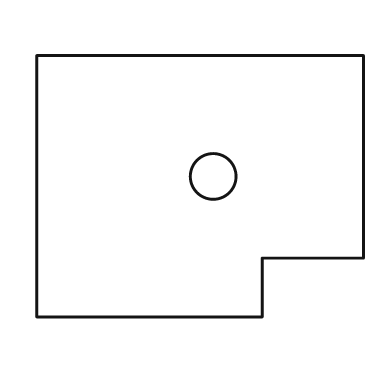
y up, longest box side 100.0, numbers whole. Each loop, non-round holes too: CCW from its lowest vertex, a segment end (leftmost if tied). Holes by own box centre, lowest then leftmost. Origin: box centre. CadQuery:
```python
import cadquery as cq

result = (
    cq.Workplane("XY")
    .moveTo(-50.0, -40.0)
    .lineTo(19.0, -40.0)
    .lineTo(19.0, -22.0)
    .lineTo(50.0, -22.0)
    .lineTo(50.0, 40.0)
    .lineTo(-50.0, 40.0)
    .close()
    .moveTo(4.0, 3.0)
    .circle(7.0)
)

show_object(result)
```